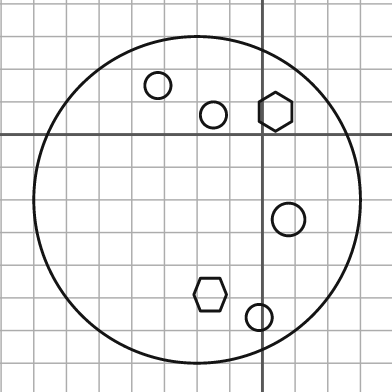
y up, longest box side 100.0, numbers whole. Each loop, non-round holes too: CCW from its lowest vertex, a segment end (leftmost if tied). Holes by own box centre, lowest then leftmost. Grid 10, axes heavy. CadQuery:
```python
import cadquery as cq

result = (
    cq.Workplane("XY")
    .moveTo(-20.0, -20.0)
    .circle(50.0)
    .moveTo(-1.0, -56.0)
    .circle(4.0)
    .moveTo(-19.0, -54.0)
    .lineTo(-13.0, -54.0)
    .lineTo(-11.0, -49.0)
    .lineTo(-13.0, -44.0)
    .lineTo(-19.0, -44.0)
    .lineTo(-21.0, -49.0)
    .close()
    .moveTo(8.0, -26.0)
    .circle(5.0)
    .moveTo(-15.0, 6.0)
    .circle(4.0)
    .moveTo(4.0, 1.0)
    .lineTo(9.0, 4.0)
    .lineTo(9.0, 10.0)
    .lineTo(4.0, 13.0)
    .lineTo(-1.0, 10.0)
    .lineTo(-1.0, 4.0)
    .close()
    .moveTo(-32.0, 15.0)
    .circle(4.0)
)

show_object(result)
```